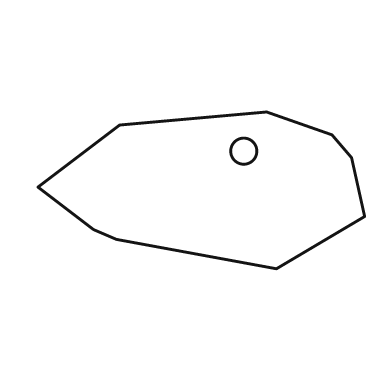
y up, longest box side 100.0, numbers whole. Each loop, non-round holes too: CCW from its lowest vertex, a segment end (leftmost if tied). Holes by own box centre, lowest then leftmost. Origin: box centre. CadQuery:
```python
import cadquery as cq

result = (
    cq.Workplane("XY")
    .moveTo(23.0, -24.0)
    .lineTo(50.0, -8.0)
    .lineTo(46.0, 10.0)
    .lineTo(40.0, 17.0)
    .lineTo(20.0, 24.0)
    .lineTo(-25.0, 20.0)
    .lineTo(-50.0, 1.0)
    .lineTo(-33.0, -12.0)
    .lineTo(-26.0, -15.0)
    .close()
    .moveTo(13.0, 12.0)
    .circle(4.0)
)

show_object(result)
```